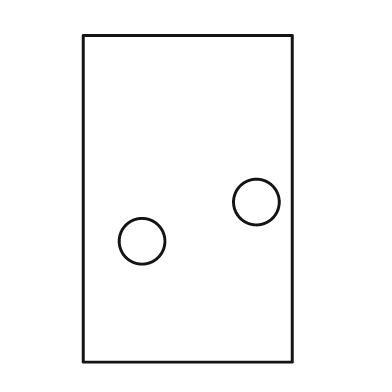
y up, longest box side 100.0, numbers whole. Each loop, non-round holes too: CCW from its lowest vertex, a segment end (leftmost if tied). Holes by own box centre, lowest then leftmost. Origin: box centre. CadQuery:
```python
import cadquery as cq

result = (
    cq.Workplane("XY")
    .moveTo(-32.0, -50.0)
    .lineTo(32.0, -50.0)
    .lineTo(32.0, 50.0)
    .lineTo(-32.0, 50.0)
    .close()
    .moveTo(-14.0, -13.0)
    .circle(7.0)
    .moveTo(21.0, -1.0)
    .circle(7.0)
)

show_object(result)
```